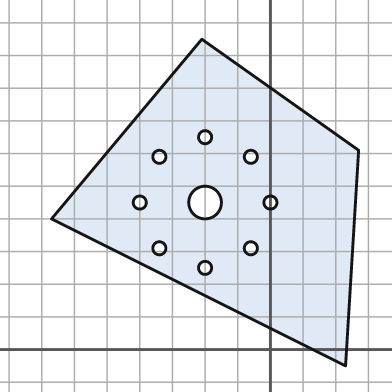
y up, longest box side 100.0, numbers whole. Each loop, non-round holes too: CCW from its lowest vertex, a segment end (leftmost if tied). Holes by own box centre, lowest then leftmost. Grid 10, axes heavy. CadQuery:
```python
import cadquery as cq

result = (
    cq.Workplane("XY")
    .moveTo(23.0, -5.0)
    .lineTo(27.0, 61.0)
    .lineTo(-21.0, 95.0)
    .lineTo(-67.0, 40.0)
    .close()
    .moveTo(-20.0, 25.0)
    .circle(2.0)
    .moveTo(-34.0, 31.0)
    .circle(2.0)
    .moveTo(-6.0, 31.0)
    .circle(2.0)
    .moveTo(-40.0, 45.0)
    .circle(2.0)
    .moveTo(-20.0, 45.0)
    .circle(5.0)
    .moveTo(0.0, 45.0)
    .circle(2.0)
    .moveTo(-34.0, 59.0)
    .circle(2.0)
    .moveTo(-6.0, 59.0)
    .circle(2.0)
    .moveTo(-20.0, 65.0)
    .circle(2.0)
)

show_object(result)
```